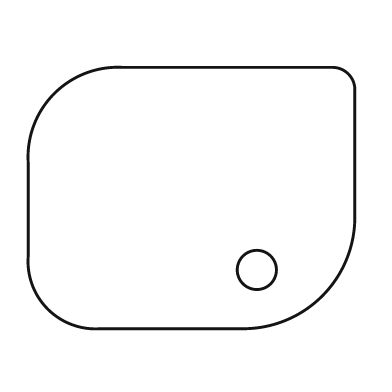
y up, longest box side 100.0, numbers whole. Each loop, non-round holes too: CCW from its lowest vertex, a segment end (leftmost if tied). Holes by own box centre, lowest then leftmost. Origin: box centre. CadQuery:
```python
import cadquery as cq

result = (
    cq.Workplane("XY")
    .moveTo(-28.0, -40.0)
    .lineTo(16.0, -40.0)
    .threePointArc((40.0, -30.0), (50.0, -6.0))
    .lineTo(50.0, 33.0)
    .threePointArc((48.0, 38.0), (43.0, 40.0))
    .lineTo(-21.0, 40.0)
    .threePointArc((-42.0, 32.0), (-50.0, 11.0))
    .lineTo(-50.0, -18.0)
    .threePointArc((-44.0, -34.0), (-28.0, -40.0))
    .close()
    .moveTo(20.0, -22.0)
    .circle(6.0)
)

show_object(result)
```